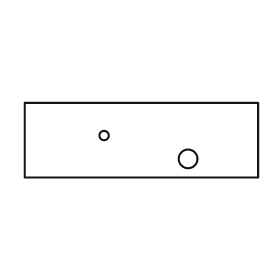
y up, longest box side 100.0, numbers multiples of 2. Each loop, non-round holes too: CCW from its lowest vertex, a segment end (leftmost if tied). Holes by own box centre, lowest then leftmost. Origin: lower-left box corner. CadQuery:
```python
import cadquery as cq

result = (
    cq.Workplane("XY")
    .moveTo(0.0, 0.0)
    .lineTo(100.0, 0.0)
    .lineTo(100.0, 32.0)
    .lineTo(0.0, 32.0)
    .close()
    .moveTo(70.0, 8.0)
    .circle(4.0)
    .moveTo(34.0, 18.0)
    .circle(2.0)
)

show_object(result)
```